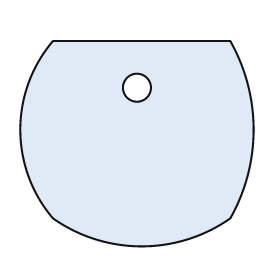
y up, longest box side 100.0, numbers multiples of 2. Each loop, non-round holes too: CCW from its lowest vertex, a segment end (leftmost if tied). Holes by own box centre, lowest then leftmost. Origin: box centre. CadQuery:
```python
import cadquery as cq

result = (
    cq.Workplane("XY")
    .moveTo(-36.0, -32.0)
    .threePointArc((2.0, -44.0), (40.0, -32.0))
    .threePointArc((50.0, 6.0), (40.0, 44.0))
    .lineTo(-36.0, 44.0)
    .threePointArc((-50.0, 6.0), (-36.0, -32.0))
    .close()
    .moveTo(0.0, 24.0)
    .circle(6.0)
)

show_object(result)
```